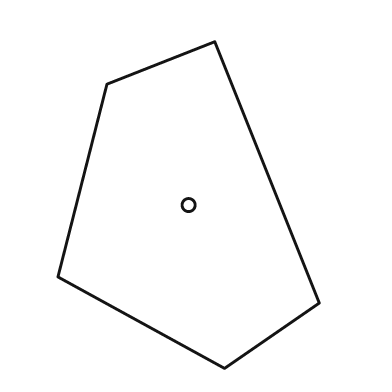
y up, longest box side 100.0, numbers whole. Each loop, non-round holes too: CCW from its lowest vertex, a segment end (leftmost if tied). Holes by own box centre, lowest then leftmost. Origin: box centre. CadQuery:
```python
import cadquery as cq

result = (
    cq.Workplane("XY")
    .moveTo(11.0, -50.0)
    .lineTo(40.0, -30.0)
    .lineTo(8.0, 50.0)
    .lineTo(-25.0, 37.0)
    .lineTo(-40.0, -22.0)
    .close()
    .moveTo(0.0, 0.0)
    .circle(2.0)
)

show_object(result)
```